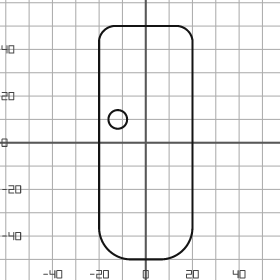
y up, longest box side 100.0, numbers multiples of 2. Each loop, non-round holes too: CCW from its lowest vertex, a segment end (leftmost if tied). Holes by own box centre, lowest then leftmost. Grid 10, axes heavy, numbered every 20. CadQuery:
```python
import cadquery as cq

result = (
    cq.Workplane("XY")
    .moveTo(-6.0, -50.0)
    .lineTo(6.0, -50.0)
    .threePointArc((16.0, -46.0), (20.0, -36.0))
    .lineTo(20.0, 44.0)
    .threePointArc((18.0, 48.0), (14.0, 50.0))
    .lineTo(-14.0, 50.0)
    .threePointArc((-18.0, 48.0), (-20.0, 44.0))
    .lineTo(-20.0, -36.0)
    .threePointArc((-16.0, -46.0), (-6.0, -50.0))
    .close()
    .moveTo(-12.0, 10.0)
    .circle(4.0)
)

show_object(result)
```